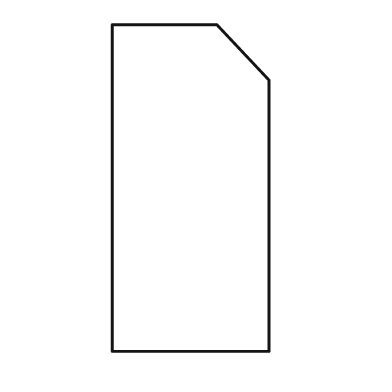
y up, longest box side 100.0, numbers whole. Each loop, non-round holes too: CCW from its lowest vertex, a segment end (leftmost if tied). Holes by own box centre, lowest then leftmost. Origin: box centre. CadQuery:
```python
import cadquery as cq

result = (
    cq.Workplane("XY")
    .moveTo(-24.0, -50.0)
    .lineTo(24.0, -50.0)
    .lineTo(24.0, 33.0)
    .lineTo(8.0, 50.0)
    .lineTo(-24.0, 50.0)
    .close()
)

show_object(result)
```